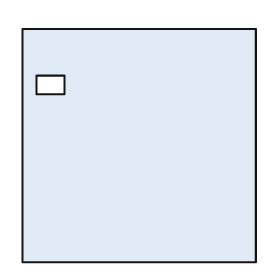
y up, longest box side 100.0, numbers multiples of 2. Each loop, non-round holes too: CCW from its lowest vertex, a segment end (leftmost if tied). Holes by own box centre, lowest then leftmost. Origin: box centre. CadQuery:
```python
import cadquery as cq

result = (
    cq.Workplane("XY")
    .moveTo(-50.0, -50.0)
    .lineTo(50.0, -50.0)
    .lineTo(50.0, 50.0)
    .lineTo(-50.0, 50.0)
    .close()
    .moveTo(-44.0, 22.0)
    .lineTo(-32.0, 22.0)
    .lineTo(-32.0, 30.0)
    .lineTo(-44.0, 30.0)
    .close()
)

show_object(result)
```